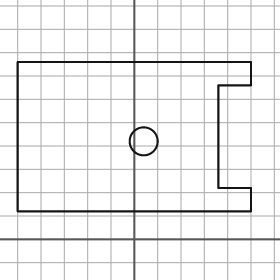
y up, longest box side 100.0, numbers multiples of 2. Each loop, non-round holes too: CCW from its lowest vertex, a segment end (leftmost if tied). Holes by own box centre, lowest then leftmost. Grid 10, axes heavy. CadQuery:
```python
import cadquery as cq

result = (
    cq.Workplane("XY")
    .moveTo(-50.0, 12.0)
    .lineTo(50.0, 12.0)
    .lineTo(50.0, 22.0)
    .lineTo(36.0, 22.0)
    .lineTo(36.0, 66.0)
    .lineTo(50.0, 66.0)
    .lineTo(50.0, 76.0)
    .lineTo(-50.0, 76.0)
    .close()
    .moveTo(4.0, 42.0)
    .circle(6.0)
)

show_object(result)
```